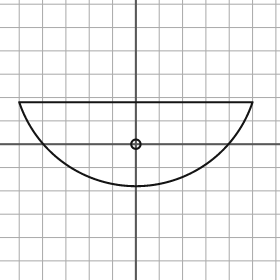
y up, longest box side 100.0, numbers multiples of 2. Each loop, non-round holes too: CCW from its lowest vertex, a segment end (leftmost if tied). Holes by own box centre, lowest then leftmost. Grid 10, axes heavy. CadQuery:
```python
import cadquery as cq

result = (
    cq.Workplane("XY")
    .moveTo(-50.0, 18.0)
    .threePointArc((0.0, -18.0), (50.0, 18.0))
    .close()
    .moveTo(0.0, 0.0)
    .circle(2.0)
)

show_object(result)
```